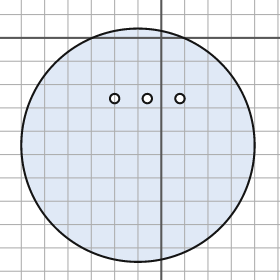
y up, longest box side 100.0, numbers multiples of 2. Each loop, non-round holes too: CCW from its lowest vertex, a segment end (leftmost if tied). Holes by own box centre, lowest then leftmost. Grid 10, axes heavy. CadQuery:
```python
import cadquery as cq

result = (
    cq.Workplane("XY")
    .moveTo(-10.0, -46.0)
    .circle(50.0)
    .moveTo(-20.0, -26.0)
    .circle(2.0)
    .moveTo(-6.0, -26.0)
    .circle(2.0)
    .moveTo(8.0, -26.0)
    .circle(2.0)
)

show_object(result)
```